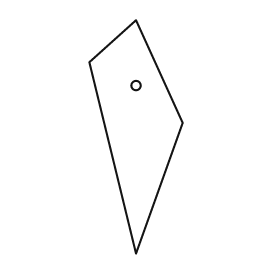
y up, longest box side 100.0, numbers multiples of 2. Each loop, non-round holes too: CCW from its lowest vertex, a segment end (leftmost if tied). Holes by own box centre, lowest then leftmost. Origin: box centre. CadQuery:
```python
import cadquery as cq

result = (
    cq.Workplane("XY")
    .moveTo(0.0, -50.0)
    .lineTo(20.0, 6.0)
    .lineTo(0.0, 50.0)
    .lineTo(-20.0, 32.0)
    .close()
    .moveTo(0.0, 22.0)
    .circle(2.0)
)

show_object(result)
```